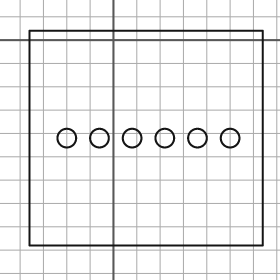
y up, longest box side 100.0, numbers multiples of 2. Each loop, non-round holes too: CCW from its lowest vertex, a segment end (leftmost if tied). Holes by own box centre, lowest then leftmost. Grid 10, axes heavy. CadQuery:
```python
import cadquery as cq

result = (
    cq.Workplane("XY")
    .moveTo(-36.0, -88.0)
    .lineTo(64.0, -88.0)
    .lineTo(64.0, 4.0)
    .lineTo(-36.0, 4.0)
    .close()
    .moveTo(-20.0, -42.0)
    .circle(4.0)
    .moveTo(-6.0, -42.0)
    .circle(4.0)
    .moveTo(8.0, -42.0)
    .circle(4.0)
    .moveTo(22.0, -42.0)
    .circle(4.0)
    .moveTo(36.0, -42.0)
    .circle(4.0)
    .moveTo(50.0, -42.0)
    .circle(4.0)
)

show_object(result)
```